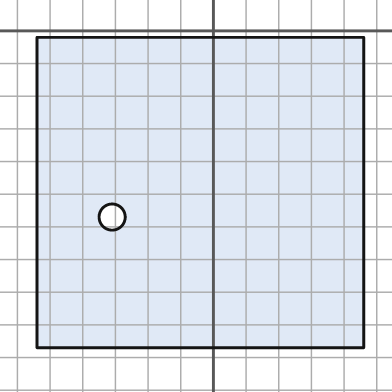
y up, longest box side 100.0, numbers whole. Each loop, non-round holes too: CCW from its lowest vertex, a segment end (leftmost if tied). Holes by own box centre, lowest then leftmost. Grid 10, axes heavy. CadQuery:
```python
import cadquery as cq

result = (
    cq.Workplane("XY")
    .moveTo(-54.0, -97.0)
    .lineTo(46.0, -97.0)
    .lineTo(46.0, -2.0)
    .lineTo(-54.0, -2.0)
    .close()
    .moveTo(-31.0, -57.0)
    .circle(4.0)
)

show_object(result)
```